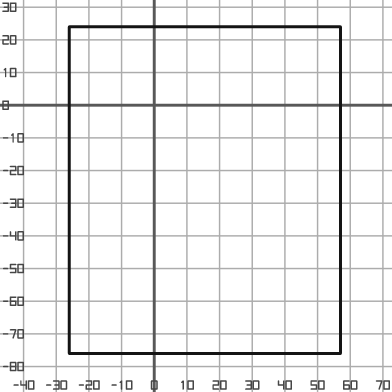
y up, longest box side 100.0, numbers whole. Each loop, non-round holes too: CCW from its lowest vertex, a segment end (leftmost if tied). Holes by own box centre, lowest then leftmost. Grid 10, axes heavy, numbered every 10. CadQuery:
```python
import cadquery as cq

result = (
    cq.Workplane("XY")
    .moveTo(-26.0, -76.0)
    .lineTo(57.0, -76.0)
    .lineTo(57.0, 24.0)
    .lineTo(-26.0, 24.0)
    .close()
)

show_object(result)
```